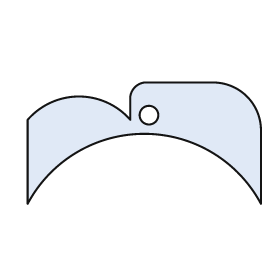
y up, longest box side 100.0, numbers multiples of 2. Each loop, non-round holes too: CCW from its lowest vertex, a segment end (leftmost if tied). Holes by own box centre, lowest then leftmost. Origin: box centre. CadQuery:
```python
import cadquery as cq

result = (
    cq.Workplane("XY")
    .moveTo(-50.0, -26.0)
    .threePointArc((0.0, 4.0), (50.0, -26.0))
    .lineTo(50.0, 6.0)
    .threePointArc((44.0, 20.0), (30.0, 26.0))
    .lineTo(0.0, 26.0)
    .threePointArc((-4.0, 24.0), (-6.0, 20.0))
    .lineTo(-6.0, 10.0)
    .threePointArc((-28.0, 20.0), (-50.0, 10.0))
    .close()
    .moveTo(2.0, 12.0)
    .circle(4.0)
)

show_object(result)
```